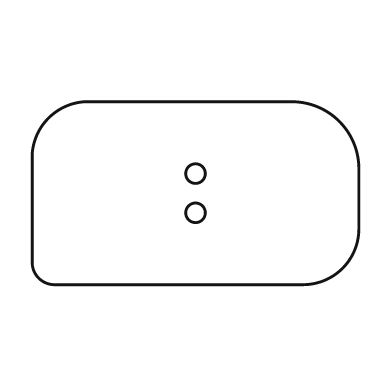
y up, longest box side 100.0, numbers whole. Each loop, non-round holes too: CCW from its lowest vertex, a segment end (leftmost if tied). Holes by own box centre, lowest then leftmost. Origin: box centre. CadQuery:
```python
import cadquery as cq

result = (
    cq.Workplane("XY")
    .moveTo(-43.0, -28.0)
    .lineTo(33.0, -28.0)
    .threePointArc((45.0, -23.0), (50.0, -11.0))
    .lineTo(50.0, 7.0)
    .threePointArc((44.0, 22.0), (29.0, 28.0))
    .lineTo(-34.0, 28.0)
    .threePointArc((-45.0, 23.0), (-50.0, 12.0))
    .lineTo(-50.0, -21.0)
    .threePointArc((-48.0, -26.0), (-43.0, -28.0))
    .close()
    .moveTo(0.0, -6.0)
    .circle(3.0)
    .moveTo(0.0, 6.0)
    .circle(3.0)
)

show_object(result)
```